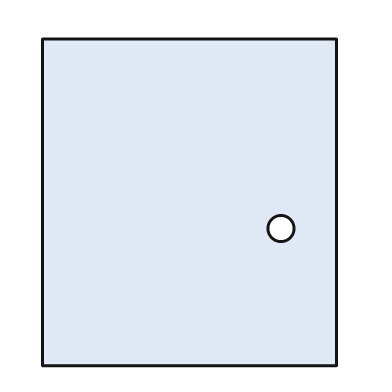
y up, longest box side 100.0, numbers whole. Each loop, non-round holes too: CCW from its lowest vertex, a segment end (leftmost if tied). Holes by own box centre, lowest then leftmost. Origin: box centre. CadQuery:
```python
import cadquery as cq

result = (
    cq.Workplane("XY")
    .moveTo(-45.0, -50.0)
    .lineTo(45.0, -50.0)
    .lineTo(45.0, 50.0)
    .lineTo(-45.0, 50.0)
    .close()
    .moveTo(28.0, -8.0)
    .circle(4.0)
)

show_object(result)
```